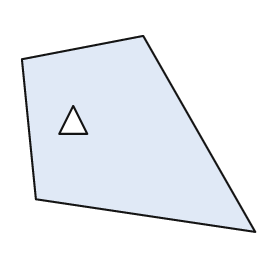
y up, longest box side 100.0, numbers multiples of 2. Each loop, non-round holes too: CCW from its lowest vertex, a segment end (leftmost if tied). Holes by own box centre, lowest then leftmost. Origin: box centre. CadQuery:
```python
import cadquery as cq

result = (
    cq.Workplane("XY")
    .moveTo(50.0, -42.0)
    .lineTo(2.0, 42.0)
    .lineTo(-50.0, 32.0)
    .lineTo(-44.0, -28.0)
    .close()
    .moveTo(-34.0, 0.0)
    .lineTo(-22.0, 0.0)
    .lineTo(-28.0, 12.0)
    .close()
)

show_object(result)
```